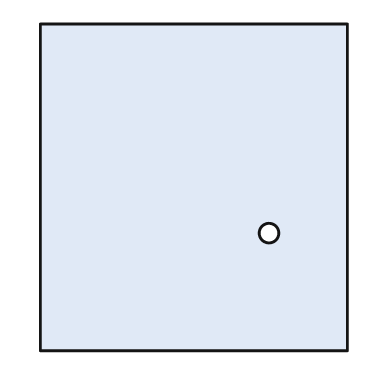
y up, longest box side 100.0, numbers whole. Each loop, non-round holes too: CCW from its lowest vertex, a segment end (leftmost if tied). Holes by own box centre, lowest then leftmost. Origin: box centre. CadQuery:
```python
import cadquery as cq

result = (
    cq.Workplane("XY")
    .moveTo(-47.0, -50.0)
    .lineTo(47.0, -50.0)
    .lineTo(47.0, 50.0)
    .lineTo(-47.0, 50.0)
    .close()
    .moveTo(23.0, -14.0)
    .circle(3.0)
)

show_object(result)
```